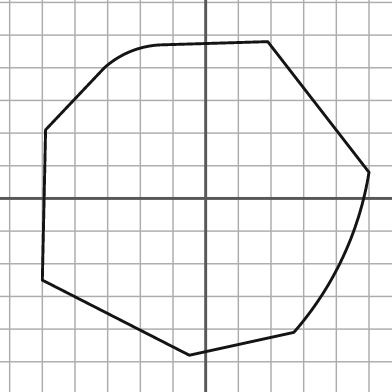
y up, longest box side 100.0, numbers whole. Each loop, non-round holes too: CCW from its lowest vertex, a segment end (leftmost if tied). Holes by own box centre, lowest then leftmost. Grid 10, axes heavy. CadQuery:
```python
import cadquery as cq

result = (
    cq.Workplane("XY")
    .moveTo(-5.0, -48.0)
    .lineTo(27.0, -41.0)
    .threePointArc((42.0, -18.0), (50.0, 8.0))
    .lineTo(19.0, 48.0)
    .lineTo(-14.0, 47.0)
    .threePointArc((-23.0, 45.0), (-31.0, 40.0))
    .lineTo(-49.0, 21.0)
    .lineTo(-50.0, -25.0)
    .close()
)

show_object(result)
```